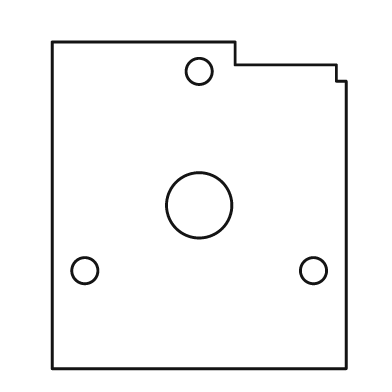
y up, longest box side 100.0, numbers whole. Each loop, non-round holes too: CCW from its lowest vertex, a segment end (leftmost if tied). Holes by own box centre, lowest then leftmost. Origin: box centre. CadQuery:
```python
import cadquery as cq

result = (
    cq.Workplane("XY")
    .moveTo(-45.0, -50.0)
    .lineTo(45.0, -50.0)
    .lineTo(45.0, 38.0)
    .lineTo(42.0, 38.0)
    .lineTo(42.0, 43.0)
    .lineTo(11.0, 43.0)
    .lineTo(11.0, 50.0)
    .lineTo(-45.0, 50.0)
    .close()
    .moveTo(-35.0, -20.0)
    .circle(4.0)
    .moveTo(35.0, -20.0)
    .circle(4.0)
    .moveTo(0.0, 0.0)
    .circle(10.0)
    .moveTo(0.0, 41.0)
    .circle(4.0)
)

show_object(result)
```